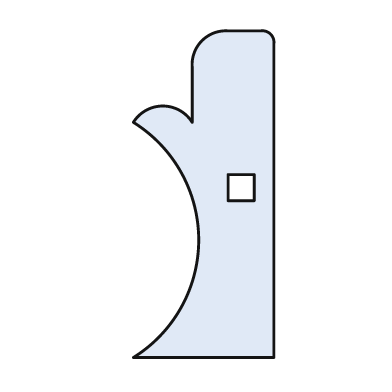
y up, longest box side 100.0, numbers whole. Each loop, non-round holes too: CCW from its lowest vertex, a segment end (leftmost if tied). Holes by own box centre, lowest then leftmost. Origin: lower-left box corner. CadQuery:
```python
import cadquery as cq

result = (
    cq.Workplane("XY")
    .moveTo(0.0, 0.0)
    .lineTo(43.0, 0.0)
    .lineTo(43.0, 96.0)
    .threePointArc((42.0, 99.0), (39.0, 100.0))
    .lineTo(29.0, 100.0)
    .threePointArc((21.0, 97.0), (18.0, 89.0))
    .lineTo(18.0, 72.0)
    .threePointArc((9.0, 77.0), (0.0, 72.0))
    .threePointArc((20.0, 36.0), (0.0, 0.0))
    .close()
    .moveTo(29.0, 48.0)
    .lineTo(37.0, 48.0)
    .lineTo(37.0, 56.0)
    .lineTo(29.0, 56.0)
    .close()
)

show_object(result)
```